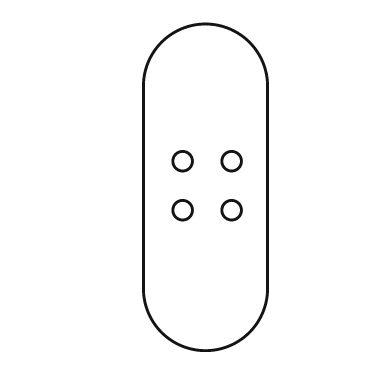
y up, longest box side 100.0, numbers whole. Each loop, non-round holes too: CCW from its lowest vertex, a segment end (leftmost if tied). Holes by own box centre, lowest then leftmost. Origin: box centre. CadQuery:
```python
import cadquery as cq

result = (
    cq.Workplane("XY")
    .moveTo(-19.0, -31.0)
    .threePointArc((0.0, -50.0), (19.0, -31.0))
    .lineTo(19.0, 31.0)
    .threePointArc((0.0, 50.0), (-19.0, 31.0))
    .close()
    .moveTo(-7.0, -7.0)
    .circle(3.0)
    .moveTo(8.0, -7.0)
    .circle(3.0)
    .moveTo(-7.0, 8.0)
    .circle(3.0)
    .moveTo(8.0, 8.0)
    .circle(3.0)
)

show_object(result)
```